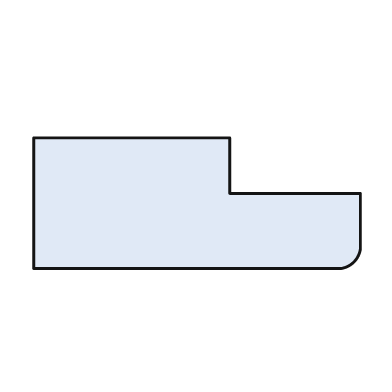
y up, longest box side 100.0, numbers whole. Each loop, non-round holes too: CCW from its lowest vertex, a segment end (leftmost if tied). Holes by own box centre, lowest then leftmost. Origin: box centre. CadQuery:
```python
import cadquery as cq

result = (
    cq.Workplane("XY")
    .moveTo(-50.0, -20.0)
    .lineTo(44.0, -20.0)
    .threePointArc((48.0, -18.0), (50.0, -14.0))
    .lineTo(50.0, 3.0)
    .lineTo(10.0, 3.0)
    .lineTo(10.0, 20.0)
    .lineTo(-50.0, 20.0)
    .close()
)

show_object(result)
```